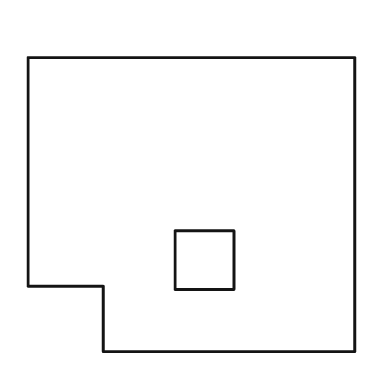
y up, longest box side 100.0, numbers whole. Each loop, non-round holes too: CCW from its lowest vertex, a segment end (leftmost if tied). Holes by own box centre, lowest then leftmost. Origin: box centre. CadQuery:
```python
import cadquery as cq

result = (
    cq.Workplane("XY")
    .moveTo(-27.0, -45.0)
    .lineTo(50.0, -45.0)
    .lineTo(50.0, 45.0)
    .lineTo(-50.0, 45.0)
    .lineTo(-50.0, -25.0)
    .lineTo(-27.0, -25.0)
    .close()
    .moveTo(-5.0, -26.0)
    .lineTo(13.0, -26.0)
    .lineTo(13.0, -8.0)
    .lineTo(-5.0, -8.0)
    .close()
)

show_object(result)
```